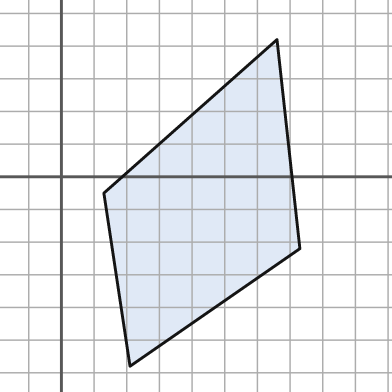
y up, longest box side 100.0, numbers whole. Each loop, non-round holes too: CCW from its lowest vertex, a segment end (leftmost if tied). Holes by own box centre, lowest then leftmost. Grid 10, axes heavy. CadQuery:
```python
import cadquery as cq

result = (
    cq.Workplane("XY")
    .moveTo(21.0, -58.0)
    .lineTo(73.0, -22.0)
    .lineTo(66.0, 42.0)
    .lineTo(13.0, -5.0)
    .close()
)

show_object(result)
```